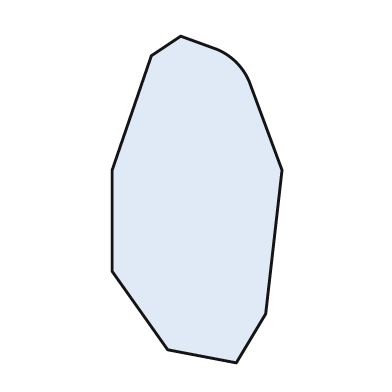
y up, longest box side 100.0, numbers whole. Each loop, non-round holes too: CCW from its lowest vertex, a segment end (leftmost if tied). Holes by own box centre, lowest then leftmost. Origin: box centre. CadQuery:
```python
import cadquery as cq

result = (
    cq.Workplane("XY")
    .moveTo(12.0, -50.0)
    .lineTo(21.0, -35.0)
    .lineTo(26.0, 9.0)
    .lineTo(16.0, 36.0)
    .threePointArc((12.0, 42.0), (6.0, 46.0))
    .lineTo(-5.0, 50.0)
    .lineTo(-14.0, 44.0)
    .lineTo(-26.0, 9.0)
    .lineTo(-26.0, -22.0)
    .lineTo(-9.0, -46.0)
    .close()
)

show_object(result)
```